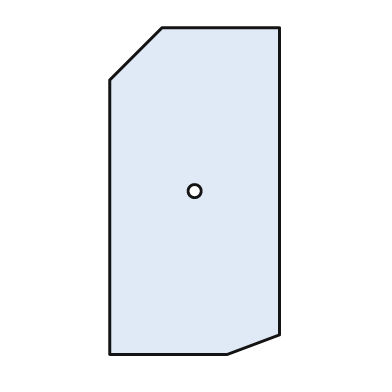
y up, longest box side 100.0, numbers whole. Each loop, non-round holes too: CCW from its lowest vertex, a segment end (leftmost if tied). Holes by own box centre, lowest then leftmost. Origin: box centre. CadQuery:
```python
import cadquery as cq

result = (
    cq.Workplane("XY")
    .moveTo(-26.0, -50.0)
    .lineTo(10.0, -50.0)
    .lineTo(26.0, -44.0)
    .lineTo(26.0, 50.0)
    .lineTo(-10.0, 50.0)
    .lineTo(-26.0, 34.0)
    .close()
    .moveTo(0.0, 0.0)
    .circle(2.0)
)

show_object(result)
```